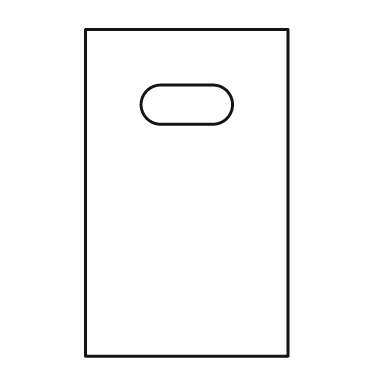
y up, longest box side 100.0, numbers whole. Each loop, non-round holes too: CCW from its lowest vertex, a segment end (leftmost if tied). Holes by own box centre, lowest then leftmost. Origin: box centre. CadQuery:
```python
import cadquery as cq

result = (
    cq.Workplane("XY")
    .moveTo(-31.0, -50.0)
    .lineTo(31.0, -50.0)
    .lineTo(31.0, 50.0)
    .lineTo(-31.0, 50.0)
    .close()
    .moveTo(-8.0, 21.0)
    .lineTo(8.0, 21.0)
    .threePointArc((14.0, 27.0), (8.0, 33.0))
    .lineTo(-8.0, 33.0)
    .threePointArc((-14.0, 27.0), (-8.0, 21.0))
    .close()
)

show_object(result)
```